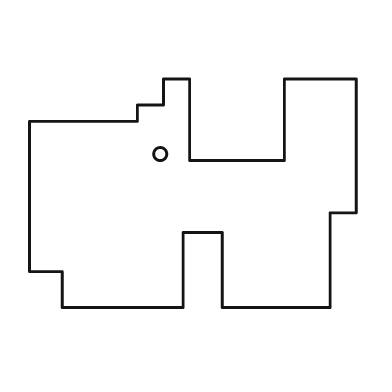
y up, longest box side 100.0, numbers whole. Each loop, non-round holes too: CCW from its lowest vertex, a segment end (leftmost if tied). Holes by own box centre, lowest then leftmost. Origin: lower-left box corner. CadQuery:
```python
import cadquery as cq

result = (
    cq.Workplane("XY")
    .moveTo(10.0, 0.0)
    .lineTo(47.0, 0.0)
    .lineTo(47.0, 23.0)
    .lineTo(59.0, 23.0)
    .lineTo(59.0, 0.0)
    .lineTo(92.0, 0.0)
    .lineTo(92.0, 29.0)
    .lineTo(100.0, 29.0)
    .lineTo(100.0, 70.0)
    .lineTo(78.0, 70.0)
    .lineTo(78.0, 45.0)
    .lineTo(49.0, 45.0)
    .lineTo(49.0, 70.0)
    .lineTo(41.0, 70.0)
    .lineTo(41.0, 62.0)
    .lineTo(33.0, 62.0)
    .lineTo(33.0, 57.0)
    .lineTo(0.0, 57.0)
    .lineTo(0.0, 11.0)
    .lineTo(10.0, 11.0)
    .close()
    .moveTo(40.0, 47.0)
    .circle(2.0)
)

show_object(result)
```